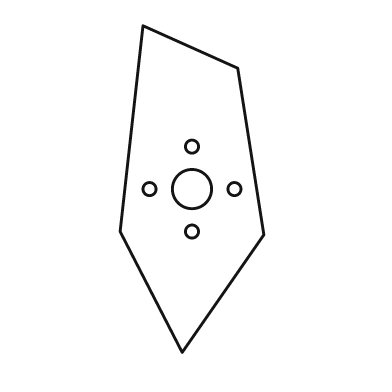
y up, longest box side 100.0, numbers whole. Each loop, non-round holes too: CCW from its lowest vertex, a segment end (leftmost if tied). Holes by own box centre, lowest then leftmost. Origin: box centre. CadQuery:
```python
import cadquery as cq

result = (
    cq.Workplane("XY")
    .moveTo(-3.0, -50.0)
    .lineTo(22.0, -14.0)
    .lineTo(14.0, 37.0)
    .lineTo(-15.0, 50.0)
    .lineTo(-22.0, -13.0)
    .close()
    .moveTo(0.0, -13.0)
    .circle(2.0)
    .moveTo(-13.0, 0.0)
    .circle(2.0)
    .moveTo(0.0, 0.0)
    .circle(6.0)
    .moveTo(13.0, 0.0)
    .circle(2.0)
    .moveTo(0.0, 13.0)
    .circle(2.0)
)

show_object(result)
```